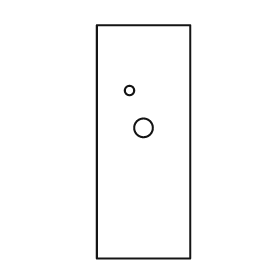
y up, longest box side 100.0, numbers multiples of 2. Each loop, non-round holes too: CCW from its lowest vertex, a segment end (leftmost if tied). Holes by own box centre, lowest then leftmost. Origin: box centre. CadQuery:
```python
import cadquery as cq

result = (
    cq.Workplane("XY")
    .moveTo(-20.0, -50.0)
    .lineTo(20.0, -50.0)
    .lineTo(20.0, 50.0)
    .lineTo(-20.0, 50.0)
    .close()
    .moveTo(0.0, 6.0)
    .circle(4.0)
    .moveTo(-6.0, 22.0)
    .circle(2.0)
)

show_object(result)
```